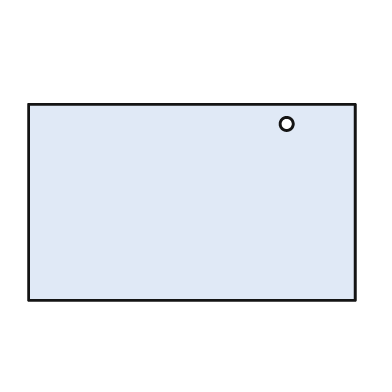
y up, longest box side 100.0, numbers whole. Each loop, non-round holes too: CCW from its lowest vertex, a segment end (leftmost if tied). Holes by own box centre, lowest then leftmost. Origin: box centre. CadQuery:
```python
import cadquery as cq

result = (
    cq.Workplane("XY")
    .moveTo(-50.0, -30.0)
    .lineTo(50.0, -30.0)
    .lineTo(50.0, 30.0)
    .lineTo(-50.0, 30.0)
    .close()
    .moveTo(29.0, 24.0)
    .circle(2.0)
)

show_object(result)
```